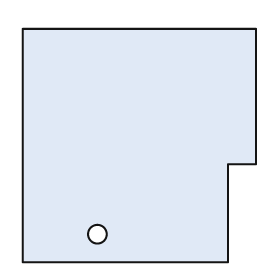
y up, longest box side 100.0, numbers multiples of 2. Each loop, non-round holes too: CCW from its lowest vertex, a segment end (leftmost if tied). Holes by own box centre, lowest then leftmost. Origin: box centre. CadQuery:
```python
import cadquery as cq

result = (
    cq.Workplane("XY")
    .moveTo(-50.0, -50.0)
    .lineTo(38.0, -50.0)
    .lineTo(38.0, -8.0)
    .lineTo(50.0, -8.0)
    .lineTo(50.0, 50.0)
    .lineTo(-50.0, 50.0)
    .close()
    .moveTo(-18.0, -38.0)
    .circle(4.0)
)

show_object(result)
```